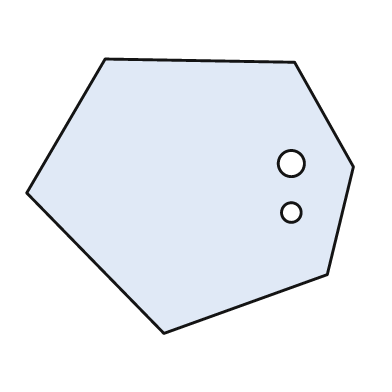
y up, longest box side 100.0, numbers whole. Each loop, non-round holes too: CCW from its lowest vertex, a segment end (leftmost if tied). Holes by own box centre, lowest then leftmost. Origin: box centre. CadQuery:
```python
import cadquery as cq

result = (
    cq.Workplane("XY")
    .moveTo(-8.0, -42.0)
    .lineTo(42.0, -24.0)
    .lineTo(50.0, 9.0)
    .lineTo(32.0, 41.0)
    .lineTo(-26.0, 42.0)
    .lineTo(-50.0, 1.0)
    .close()
    .moveTo(31.0, -5.0)
    .circle(3.0)
    .moveTo(31.0, 10.0)
    .circle(4.0)
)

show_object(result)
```